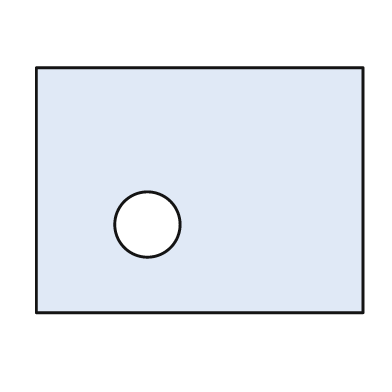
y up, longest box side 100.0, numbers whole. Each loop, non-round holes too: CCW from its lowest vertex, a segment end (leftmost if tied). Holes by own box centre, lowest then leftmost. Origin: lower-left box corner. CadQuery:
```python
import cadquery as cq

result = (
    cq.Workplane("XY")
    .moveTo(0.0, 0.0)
    .lineTo(100.0, 0.0)
    .lineTo(100.0, 75.0)
    .lineTo(0.0, 75.0)
    .close()
    .moveTo(34.0, 27.0)
    .circle(10.0)
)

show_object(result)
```